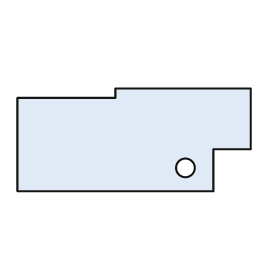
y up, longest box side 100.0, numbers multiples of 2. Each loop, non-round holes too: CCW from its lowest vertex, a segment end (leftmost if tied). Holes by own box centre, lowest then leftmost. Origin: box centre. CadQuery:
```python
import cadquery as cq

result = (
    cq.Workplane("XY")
    .moveTo(-50.0, -22.0)
    .lineTo(34.0, -22.0)
    .lineTo(34.0, -4.0)
    .lineTo(50.0, -4.0)
    .lineTo(50.0, 22.0)
    .lineTo(-8.0, 22.0)
    .lineTo(-8.0, 18.0)
    .lineTo(-50.0, 18.0)
    .close()
    .moveTo(22.0, -12.0)
    .circle(4.0)
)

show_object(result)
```